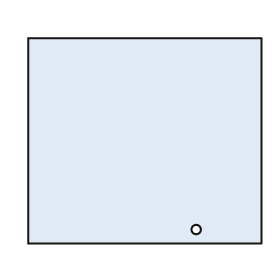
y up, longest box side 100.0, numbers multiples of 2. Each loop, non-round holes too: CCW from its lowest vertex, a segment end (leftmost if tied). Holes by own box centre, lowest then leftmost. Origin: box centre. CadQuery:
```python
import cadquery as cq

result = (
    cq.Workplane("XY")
    .moveTo(-50.0, -44.0)
    .lineTo(50.0, -44.0)
    .lineTo(50.0, 44.0)
    .lineTo(-50.0, 44.0)
    .close()
    .moveTo(22.0, -38.0)
    .circle(2.0)
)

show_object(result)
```